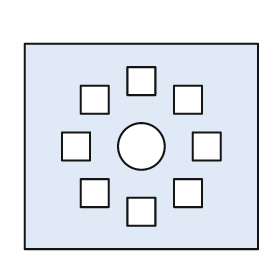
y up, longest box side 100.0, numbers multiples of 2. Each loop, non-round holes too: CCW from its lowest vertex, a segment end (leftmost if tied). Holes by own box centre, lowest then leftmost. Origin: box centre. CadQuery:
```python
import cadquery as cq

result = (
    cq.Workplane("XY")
    .moveTo(-50.0, -44.0)
    .lineTo(50.0, -44.0)
    .lineTo(50.0, 44.0)
    .lineTo(-50.0, 44.0)
    .close()
    .moveTo(-6.0, -34.0)
    .lineTo(6.0, -34.0)
    .lineTo(6.0, -22.0)
    .lineTo(-6.0, -22.0)
    .close()
    .moveTo(-26.0, -26.0)
    .lineTo(-14.0, -26.0)
    .lineTo(-14.0, -14.0)
    .lineTo(-26.0, -14.0)
    .close()
    .moveTo(14.0, -26.0)
    .lineTo(26.0, -26.0)
    .lineTo(26.0, -14.0)
    .lineTo(14.0, -14.0)
    .close()
    .moveTo(-34.0, -6.0)
    .lineTo(-22.0, -6.0)
    .lineTo(-22.0, 6.0)
    .lineTo(-34.0, 6.0)
    .close()
    .moveTo(0.0, 0.0)
    .circle(10.0)
    .moveTo(22.0, -6.0)
    .lineTo(34.0, -6.0)
    .lineTo(34.0, 6.0)
    .lineTo(22.0, 6.0)
    .close()
    .moveTo(-26.0, 14.0)
    .lineTo(-14.0, 14.0)
    .lineTo(-14.0, 26.0)
    .lineTo(-26.0, 26.0)
    .close()
    .moveTo(14.0, 14.0)
    .lineTo(26.0, 14.0)
    .lineTo(26.0, 26.0)
    .lineTo(14.0, 26.0)
    .close()
    .moveTo(-6.0, 22.0)
    .lineTo(6.0, 22.0)
    .lineTo(6.0, 34.0)
    .lineTo(-6.0, 34.0)
    .close()
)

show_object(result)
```